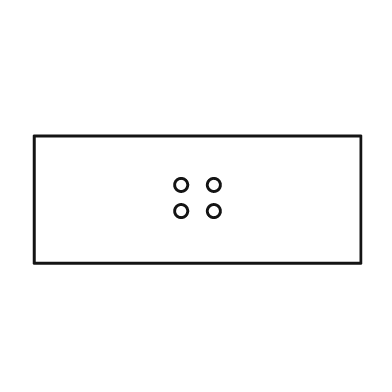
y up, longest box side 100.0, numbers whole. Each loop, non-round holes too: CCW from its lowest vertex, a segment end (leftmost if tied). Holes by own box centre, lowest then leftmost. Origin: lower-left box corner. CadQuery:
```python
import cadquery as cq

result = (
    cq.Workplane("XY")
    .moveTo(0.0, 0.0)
    .lineTo(100.0, 0.0)
    .lineTo(100.0, 39.0)
    .lineTo(0.0, 39.0)
    .close()
    .moveTo(45.0, 16.0)
    .circle(2.0)
    .moveTo(55.0, 16.0)
    .circle(2.0)
    .moveTo(45.0, 24.0)
    .circle(2.0)
    .moveTo(55.0, 24.0)
    .circle(2.0)
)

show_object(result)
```